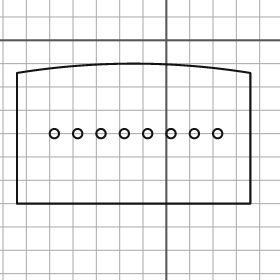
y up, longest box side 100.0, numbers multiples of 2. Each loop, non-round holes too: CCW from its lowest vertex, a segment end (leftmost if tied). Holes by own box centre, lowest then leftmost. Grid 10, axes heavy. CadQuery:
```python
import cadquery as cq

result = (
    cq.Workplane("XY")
    .moveTo(-64.0, -70.0)
    .lineTo(36.0, -70.0)
    .lineTo(36.0, -14.0)
    .threePointArc((-14.0, -10.0), (-64.0, -14.0))
    .close()
    .moveTo(-48.0, -40.0)
    .circle(2.0)
    .moveTo(-38.0, -40.0)
    .circle(2.0)
    .moveTo(-28.0, -40.0)
    .circle(2.0)
    .moveTo(-18.0, -40.0)
    .circle(2.0)
    .moveTo(-8.0, -40.0)
    .circle(2.0)
    .moveTo(2.0, -40.0)
    .circle(2.0)
    .moveTo(12.0, -40.0)
    .circle(2.0)
    .moveTo(22.0, -40.0)
    .circle(2.0)
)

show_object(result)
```